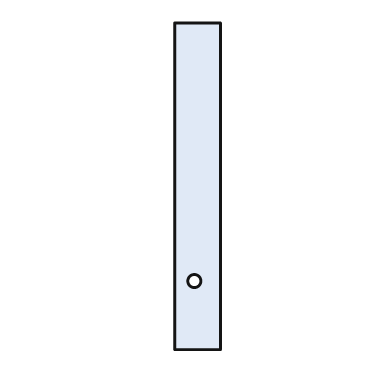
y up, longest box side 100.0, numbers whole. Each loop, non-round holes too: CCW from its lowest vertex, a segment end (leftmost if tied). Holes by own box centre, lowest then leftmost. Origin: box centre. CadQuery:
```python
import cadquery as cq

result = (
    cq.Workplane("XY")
    .moveTo(-7.0, -50.0)
    .lineTo(7.0, -50.0)
    .lineTo(7.0, 50.0)
    .lineTo(-7.0, 50.0)
    .close()
    .moveTo(-1.0, -29.0)
    .circle(2.0)
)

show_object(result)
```